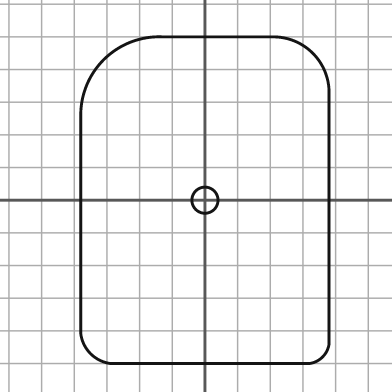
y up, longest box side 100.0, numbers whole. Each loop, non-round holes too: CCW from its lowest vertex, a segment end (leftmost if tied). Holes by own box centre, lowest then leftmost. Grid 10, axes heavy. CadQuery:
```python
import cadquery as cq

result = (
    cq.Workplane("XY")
    .moveTo(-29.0, -50.0)
    .lineTo(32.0, -50.0)
    .threePointArc((36.0, -48.0), (38.0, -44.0))
    .lineTo(38.0, 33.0)
    .threePointArc((33.0, 45.0), (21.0, 50.0))
    .lineTo(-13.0, 50.0)
    .threePointArc((-31.0, 43.0), (-38.0, 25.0))
    .lineTo(-38.0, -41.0)
    .threePointArc((-35.0, -47.0), (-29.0, -50.0))
    .close()
    .moveTo(0.0, 0.0)
    .circle(4.0)
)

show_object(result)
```